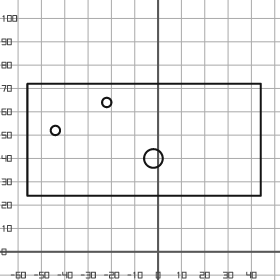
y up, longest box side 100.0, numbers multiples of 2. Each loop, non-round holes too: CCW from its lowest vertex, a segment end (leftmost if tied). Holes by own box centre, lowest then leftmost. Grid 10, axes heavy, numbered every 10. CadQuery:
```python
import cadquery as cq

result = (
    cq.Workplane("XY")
    .moveTo(-56.0, 24.0)
    .lineTo(44.0, 24.0)
    .lineTo(44.0, 72.0)
    .lineTo(-56.0, 72.0)
    .close()
    .moveTo(-2.0, 40.0)
    .circle(4.0)
    .moveTo(-44.0, 52.0)
    .circle(2.0)
    .moveTo(-22.0, 64.0)
    .circle(2.0)
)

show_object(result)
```